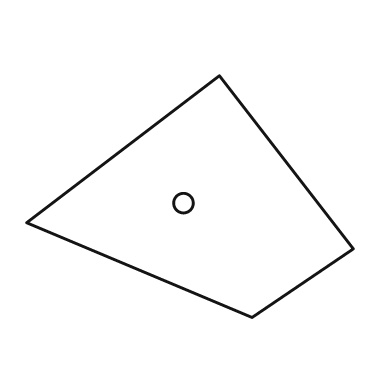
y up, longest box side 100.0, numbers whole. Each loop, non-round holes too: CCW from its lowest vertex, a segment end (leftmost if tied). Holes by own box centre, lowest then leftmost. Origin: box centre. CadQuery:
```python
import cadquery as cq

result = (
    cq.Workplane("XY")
    .moveTo(19.0, -37.0)
    .lineTo(50.0, -16.0)
    .lineTo(9.0, 37.0)
    .lineTo(-50.0, -8.0)
    .close()
    .moveTo(-2.0, -2.0)
    .circle(3.0)
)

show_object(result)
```